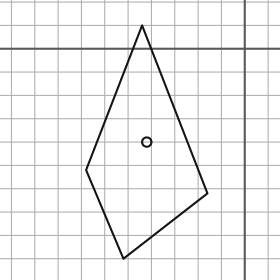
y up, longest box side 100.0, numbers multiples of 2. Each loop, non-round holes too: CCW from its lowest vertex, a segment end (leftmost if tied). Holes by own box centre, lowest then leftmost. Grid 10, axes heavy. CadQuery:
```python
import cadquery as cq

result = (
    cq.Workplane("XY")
    .moveTo(-52.0, -90.0)
    .lineTo(-16.0, -62.0)
    .lineTo(-44.0, 10.0)
    .lineTo(-68.0, -52.0)
    .close()
    .moveTo(-42.0, -40.0)
    .circle(2.0)
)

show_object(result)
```